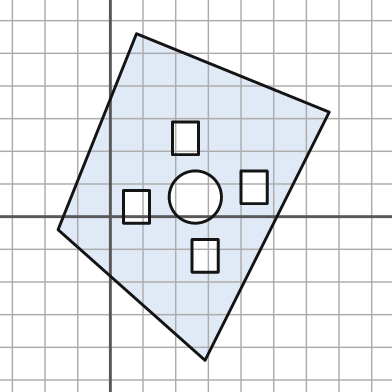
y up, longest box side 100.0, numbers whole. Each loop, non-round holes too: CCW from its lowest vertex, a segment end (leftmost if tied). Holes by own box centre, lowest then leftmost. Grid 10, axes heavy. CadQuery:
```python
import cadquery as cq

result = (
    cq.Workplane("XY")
    .moveTo(29.0, -44.0)
    .lineTo(67.0, 32.0)
    .lineTo(8.0, 56.0)
    .lineTo(-16.0, -4.0)
    .close()
    .moveTo(25.0, -17.0)
    .lineTo(33.0, -17.0)
    .lineTo(33.0, -7.0)
    .lineTo(25.0, -7.0)
    .close()
    .moveTo(4.0, -2.0)
    .lineTo(12.0, -2.0)
    .lineTo(12.0, 8.0)
    .lineTo(4.0, 8.0)
    .close()
    .moveTo(26.0, 6.0)
    .circle(8.0)
    .moveTo(40.0, 4.0)
    .lineTo(48.0, 4.0)
    .lineTo(48.0, 14.0)
    .lineTo(40.0, 14.0)
    .close()
    .moveTo(19.0, 19.0)
    .lineTo(27.0, 19.0)
    .lineTo(27.0, 29.0)
    .lineTo(19.0, 29.0)
    .close()
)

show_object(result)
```